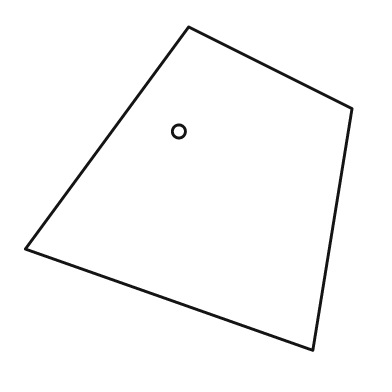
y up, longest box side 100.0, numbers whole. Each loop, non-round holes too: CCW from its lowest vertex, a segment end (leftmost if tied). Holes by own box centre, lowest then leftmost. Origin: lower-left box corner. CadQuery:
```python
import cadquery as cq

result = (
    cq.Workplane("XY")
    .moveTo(88.0, 0.0)
    .lineTo(100.0, 74.0)
    .lineTo(50.0, 99.0)
    .lineTo(0.0, 31.0)
    .close()
    .moveTo(47.0, 67.0)
    .circle(2.0)
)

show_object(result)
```